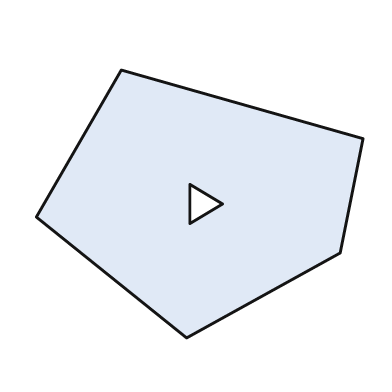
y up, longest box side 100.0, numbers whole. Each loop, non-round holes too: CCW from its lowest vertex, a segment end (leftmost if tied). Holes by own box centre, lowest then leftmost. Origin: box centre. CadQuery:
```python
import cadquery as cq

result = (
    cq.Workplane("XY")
    .moveTo(-4.0, -41.0)
    .lineTo(43.0, -15.0)
    .lineTo(50.0, 20.0)
    .lineTo(-24.0, 41.0)
    .lineTo(-50.0, -4.0)
    .close()
    .moveTo(-3.0, -6.0)
    .lineTo(7.0, 0.0)
    .lineTo(-3.0, 6.0)
    .close()
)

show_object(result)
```